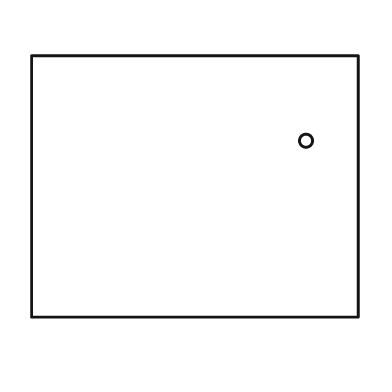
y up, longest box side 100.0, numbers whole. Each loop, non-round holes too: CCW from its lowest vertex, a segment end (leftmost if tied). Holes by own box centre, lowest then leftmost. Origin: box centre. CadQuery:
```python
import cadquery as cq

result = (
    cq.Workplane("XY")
    .moveTo(-50.0, -40.0)
    .lineTo(50.0, -40.0)
    .lineTo(50.0, 40.0)
    .lineTo(-50.0, 40.0)
    .close()
    .moveTo(34.0, 14.0)
    .circle(2.0)
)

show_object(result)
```